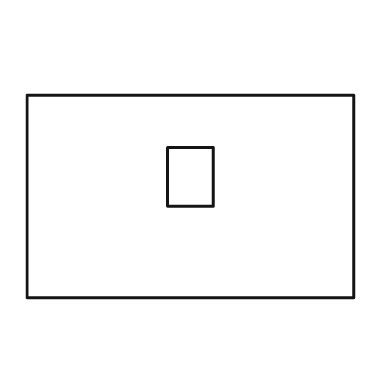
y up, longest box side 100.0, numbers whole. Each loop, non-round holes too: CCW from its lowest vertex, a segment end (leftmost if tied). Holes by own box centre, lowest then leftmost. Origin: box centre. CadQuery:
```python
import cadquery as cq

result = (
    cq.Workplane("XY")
    .moveTo(-50.0, -31.0)
    .lineTo(50.0, -31.0)
    .lineTo(50.0, 31.0)
    .lineTo(-50.0, 31.0)
    .close()
    .moveTo(-7.0, -3.0)
    .lineTo(7.0, -3.0)
    .lineTo(7.0, 15.0)
    .lineTo(-7.0, 15.0)
    .close()
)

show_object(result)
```